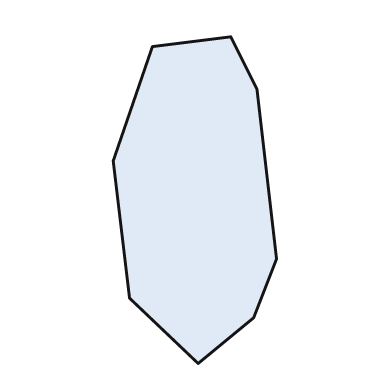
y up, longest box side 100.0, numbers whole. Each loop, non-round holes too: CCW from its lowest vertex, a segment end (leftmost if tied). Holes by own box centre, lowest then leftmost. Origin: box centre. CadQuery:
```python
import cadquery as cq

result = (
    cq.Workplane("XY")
    .moveTo(1.0, -50.0)
    .lineTo(18.0, -36.0)
    .lineTo(25.0, -18.0)
    .lineTo(19.0, 34.0)
    .lineTo(11.0, 50.0)
    .lineTo(-13.0, 47.0)
    .lineTo(-25.0, 12.0)
    .lineTo(-20.0, -30.0)
    .close()
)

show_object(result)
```